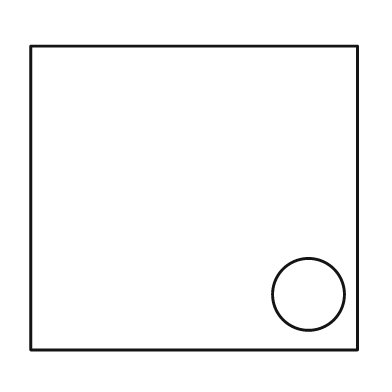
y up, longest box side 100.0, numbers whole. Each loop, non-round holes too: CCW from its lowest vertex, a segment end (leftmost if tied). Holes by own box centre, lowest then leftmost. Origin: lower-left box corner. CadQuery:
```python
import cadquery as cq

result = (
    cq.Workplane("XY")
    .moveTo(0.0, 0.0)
    .lineTo(100.0, 0.0)
    .lineTo(100.0, 93.0)
    .lineTo(0.0, 93.0)
    .close()
    .moveTo(85.0, 17.0)
    .circle(11.0)
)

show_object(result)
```